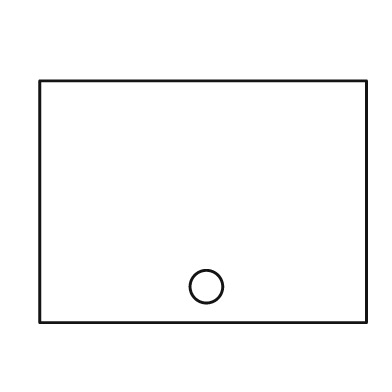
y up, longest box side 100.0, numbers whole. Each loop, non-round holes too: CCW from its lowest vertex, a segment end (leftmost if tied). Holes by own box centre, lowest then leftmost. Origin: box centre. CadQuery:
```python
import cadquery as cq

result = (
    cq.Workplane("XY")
    .moveTo(-50.0, -37.0)
    .lineTo(50.0, -37.0)
    .lineTo(50.0, 37.0)
    .lineTo(-50.0, 37.0)
    .close()
    .moveTo(1.0, -26.0)
    .circle(5.0)
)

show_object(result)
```